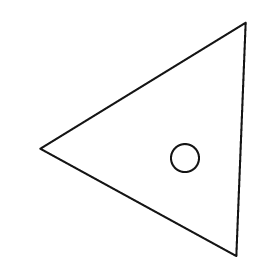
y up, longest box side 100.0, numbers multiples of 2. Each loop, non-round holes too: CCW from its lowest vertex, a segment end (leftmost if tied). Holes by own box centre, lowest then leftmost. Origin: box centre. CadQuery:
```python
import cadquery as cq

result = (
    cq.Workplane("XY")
    .moveTo(40.0, -50.0)
    .lineTo(44.0, 50.0)
    .lineTo(-44.0, -4.0)
    .close()
    .moveTo(18.0, -8.0)
    .circle(6.0)
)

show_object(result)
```